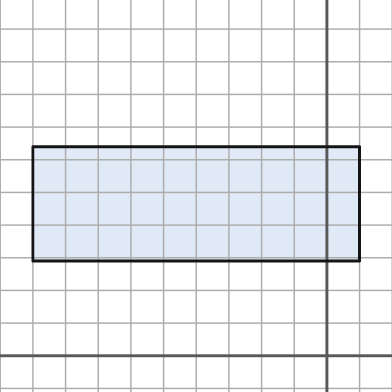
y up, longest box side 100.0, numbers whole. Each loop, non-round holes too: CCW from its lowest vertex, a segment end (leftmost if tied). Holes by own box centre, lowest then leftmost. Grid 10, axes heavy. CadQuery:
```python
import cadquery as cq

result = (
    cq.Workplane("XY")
    .moveTo(-90.0, 29.0)
    .lineTo(10.0, 29.0)
    .lineTo(10.0, 64.0)
    .lineTo(-90.0, 64.0)
    .close()
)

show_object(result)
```